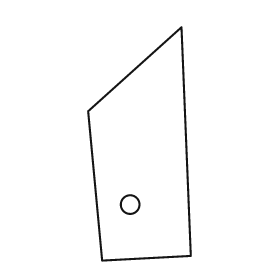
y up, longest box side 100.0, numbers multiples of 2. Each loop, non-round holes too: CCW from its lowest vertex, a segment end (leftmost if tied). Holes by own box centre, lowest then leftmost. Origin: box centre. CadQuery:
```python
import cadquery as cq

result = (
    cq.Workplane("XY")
    .moveTo(-16.0, -50.0)
    .lineTo(22.0, -48.0)
    .lineTo(18.0, 50.0)
    .lineTo(-22.0, 14.0)
    .close()
    .moveTo(-4.0, -26.0)
    .circle(4.0)
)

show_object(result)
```